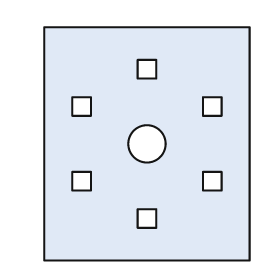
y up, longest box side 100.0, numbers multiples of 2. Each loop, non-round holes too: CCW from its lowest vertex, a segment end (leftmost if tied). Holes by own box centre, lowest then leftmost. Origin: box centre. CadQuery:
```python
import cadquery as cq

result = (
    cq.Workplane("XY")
    .moveTo(-44.0, -50.0)
    .lineTo(44.0, -50.0)
    .lineTo(44.0, 50.0)
    .lineTo(-44.0, 50.0)
    .close()
    .moveTo(-4.0, -36.0)
    .lineTo(4.0, -36.0)
    .lineTo(4.0, -28.0)
    .lineTo(-4.0, -28.0)
    .close()
    .moveTo(-32.0, -20.0)
    .lineTo(-24.0, -20.0)
    .lineTo(-24.0, -12.0)
    .lineTo(-32.0, -12.0)
    .close()
    .moveTo(24.0, -20.0)
    .lineTo(32.0, -20.0)
    .lineTo(32.0, -12.0)
    .lineTo(24.0, -12.0)
    .close()
    .moveTo(0.0, 0.0)
    .circle(8.0)
    .moveTo(-32.0, 12.0)
    .lineTo(-24.0, 12.0)
    .lineTo(-24.0, 20.0)
    .lineTo(-32.0, 20.0)
    .close()
    .moveTo(24.0, 12.0)
    .lineTo(32.0, 12.0)
    .lineTo(32.0, 20.0)
    .lineTo(24.0, 20.0)
    .close()
    .moveTo(-4.0, 28.0)
    .lineTo(4.0, 28.0)
    .lineTo(4.0, 36.0)
    .lineTo(-4.0, 36.0)
    .close()
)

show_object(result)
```